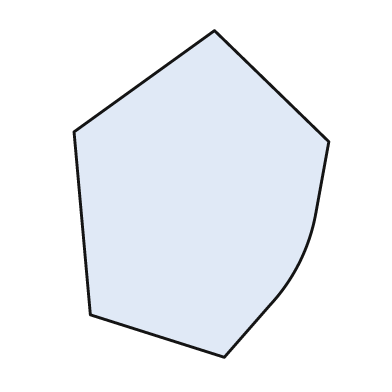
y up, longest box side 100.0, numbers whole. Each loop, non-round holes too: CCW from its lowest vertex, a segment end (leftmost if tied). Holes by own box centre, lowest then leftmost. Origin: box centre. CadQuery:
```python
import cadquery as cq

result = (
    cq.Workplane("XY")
    .moveTo(7.0, -50.0)
    .lineTo(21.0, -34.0)
    .threePointArc((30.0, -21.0), (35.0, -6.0))
    .lineTo(39.0, 16.0)
    .lineTo(4.0, 50.0)
    .lineTo(-39.0, 19.0)
    .lineTo(-34.0, -37.0)
    .close()
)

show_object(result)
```